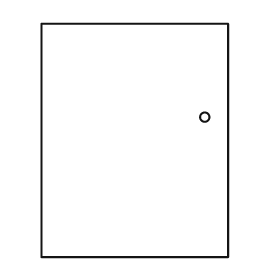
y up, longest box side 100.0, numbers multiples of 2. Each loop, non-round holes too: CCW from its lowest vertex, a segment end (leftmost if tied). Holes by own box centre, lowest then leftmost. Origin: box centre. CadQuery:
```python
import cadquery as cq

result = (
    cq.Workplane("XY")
    .moveTo(-40.0, -50.0)
    .lineTo(40.0, -50.0)
    .lineTo(40.0, 50.0)
    .lineTo(-40.0, 50.0)
    .close()
    .moveTo(30.0, 10.0)
    .circle(2.0)
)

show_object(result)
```